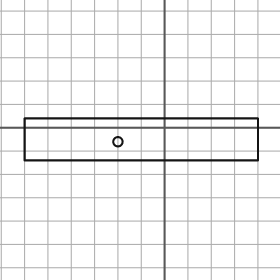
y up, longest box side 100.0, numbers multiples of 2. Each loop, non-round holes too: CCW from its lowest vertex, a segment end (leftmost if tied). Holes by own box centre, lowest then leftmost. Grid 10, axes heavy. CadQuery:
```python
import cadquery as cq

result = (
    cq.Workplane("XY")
    .moveTo(-60.0, -14.0)
    .lineTo(40.0, -14.0)
    .lineTo(40.0, 4.0)
    .lineTo(-60.0, 4.0)
    .close()
    .moveTo(-20.0, -6.0)
    .circle(2.0)
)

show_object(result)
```